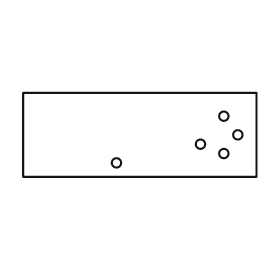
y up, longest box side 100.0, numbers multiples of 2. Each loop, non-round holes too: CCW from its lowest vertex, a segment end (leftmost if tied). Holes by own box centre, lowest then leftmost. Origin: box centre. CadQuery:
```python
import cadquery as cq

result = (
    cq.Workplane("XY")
    .moveTo(-50.0, -18.0)
    .lineTo(50.0, -18.0)
    .lineTo(50.0, 18.0)
    .lineTo(-50.0, 18.0)
    .close()
    .moveTo(-10.0, -12.0)
    .circle(2.0)
    .moveTo(36.0, -8.0)
    .circle(2.0)
    .moveTo(26.0, -4.0)
    .circle(2.0)
    .moveTo(42.0, 0.0)
    .circle(2.0)
    .moveTo(36.0, 8.0)
    .circle(2.0)
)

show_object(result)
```